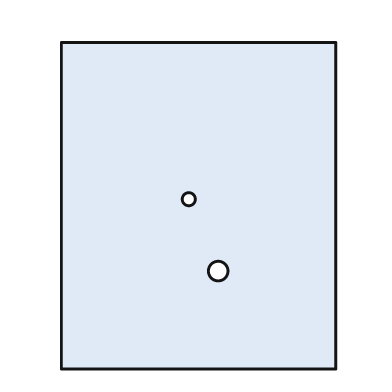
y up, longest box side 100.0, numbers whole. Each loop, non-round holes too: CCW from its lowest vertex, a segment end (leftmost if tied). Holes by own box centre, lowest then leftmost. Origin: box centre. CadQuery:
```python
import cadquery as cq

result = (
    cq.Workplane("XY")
    .moveTo(-42.0, -50.0)
    .lineTo(42.0, -50.0)
    .lineTo(42.0, 50.0)
    .lineTo(-42.0, 50.0)
    .close()
    .moveTo(6.0, -20.0)
    .circle(3.0)
    .moveTo(-3.0, 2.0)
    .circle(2.0)
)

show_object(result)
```